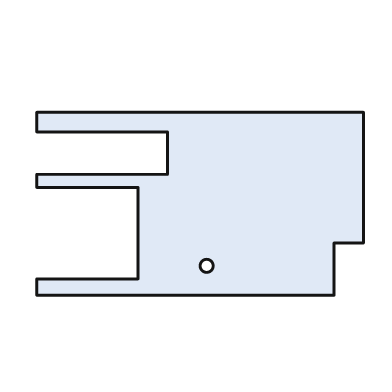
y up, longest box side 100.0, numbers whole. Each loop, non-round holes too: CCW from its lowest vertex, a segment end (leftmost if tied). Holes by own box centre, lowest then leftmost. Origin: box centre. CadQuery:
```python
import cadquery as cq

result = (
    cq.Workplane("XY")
    .moveTo(-50.0, -28.0)
    .lineTo(41.0, -28.0)
    .lineTo(41.0, -12.0)
    .lineTo(50.0, -12.0)
    .lineTo(50.0, 28.0)
    .lineTo(-50.0, 28.0)
    .lineTo(-50.0, 22.0)
    .lineTo(-10.0, 22.0)
    .lineTo(-10.0, 9.0)
    .lineTo(-50.0, 9.0)
    .lineTo(-50.0, 5.0)
    .lineTo(-19.0, 5.0)
    .lineTo(-19.0, -23.0)
    .lineTo(-50.0, -23.0)
    .close()
    .moveTo(2.0, -19.0)
    .circle(2.0)
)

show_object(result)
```